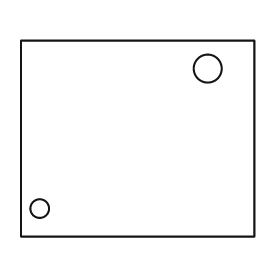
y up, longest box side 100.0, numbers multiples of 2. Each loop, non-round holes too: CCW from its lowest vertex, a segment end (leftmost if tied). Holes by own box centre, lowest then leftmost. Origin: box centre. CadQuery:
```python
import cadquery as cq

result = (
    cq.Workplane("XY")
    .moveTo(-50.0, -42.0)
    .lineTo(50.0, -42.0)
    .lineTo(50.0, 42.0)
    .lineTo(-50.0, 42.0)
    .close()
    .moveTo(-42.0, -30.0)
    .circle(4.0)
    .moveTo(30.0, 30.0)
    .circle(6.0)
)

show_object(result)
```